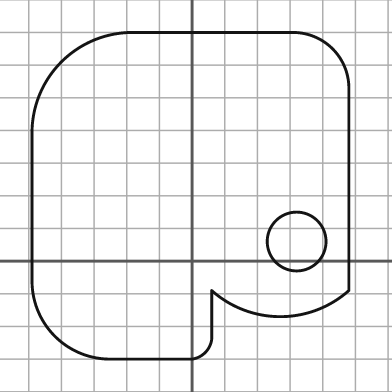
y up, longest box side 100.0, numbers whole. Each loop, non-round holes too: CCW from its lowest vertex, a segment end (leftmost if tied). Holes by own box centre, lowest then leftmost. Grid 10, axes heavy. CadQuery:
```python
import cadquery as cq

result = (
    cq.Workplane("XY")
    .moveTo(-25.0, -30.0)
    .lineTo(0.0, -30.0)
    .threePointArc((4.0, -28.0), (6.0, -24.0))
    .lineTo(6.0, -9.0)
    .threePointArc((27.0, -17.0), (48.0, -9.0))
    .lineTo(48.0, 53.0)
    .threePointArc((43.0, 65.0), (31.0, 70.0))
    .lineTo(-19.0, 70.0)
    .threePointArc((-40.0, 61.0), (-49.0, 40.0))
    .lineTo(-49.0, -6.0)
    .threePointArc((-42.0, -23.0), (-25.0, -30.0))
    .close()
    .moveTo(32.0, 6.0)
    .circle(9.0)
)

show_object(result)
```